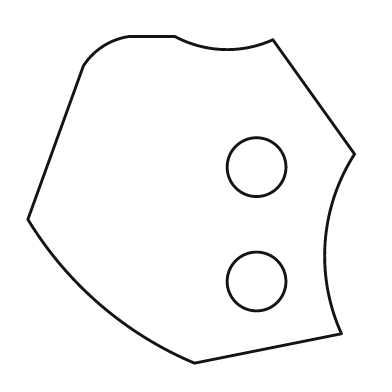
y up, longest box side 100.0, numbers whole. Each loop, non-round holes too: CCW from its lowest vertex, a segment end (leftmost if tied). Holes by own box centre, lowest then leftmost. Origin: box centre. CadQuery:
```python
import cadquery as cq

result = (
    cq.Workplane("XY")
    .moveTo(1.0, -50.0)
    .lineTo(46.0, -41.0)
    .threePointArc((41.0, -13.0), (50.0, 14.0))
    .lineTo(25.0, 49.0)
    .threePointArc((10.0, 46.0), (-5.0, 50.0))
    .lineTo(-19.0, 50.0)
    .threePointArc((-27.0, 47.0), (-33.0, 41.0))
    .lineTo(-50.0, -6.0)
    .threePointArc((-28.0, -32.0), (1.0, -50.0))
    .close()
    .moveTo(20.0, -25.0)
    .circle(9.0)
    .moveTo(20.0, 10.0)
    .circle(9.0)
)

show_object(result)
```